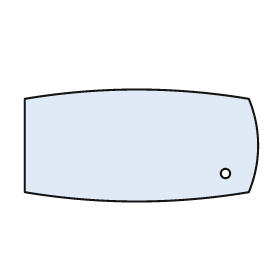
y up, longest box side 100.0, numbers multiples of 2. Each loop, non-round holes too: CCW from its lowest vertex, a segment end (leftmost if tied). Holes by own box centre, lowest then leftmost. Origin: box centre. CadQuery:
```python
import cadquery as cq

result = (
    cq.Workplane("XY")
    .moveTo(-50.0, -20.0)
    .threePointArc((-2.0, -24.0), (46.0, -20.0))
    .threePointArc((50.0, 0.0), (46.0, 20.0))
    .threePointArc((-2.0, 24.0), (-50.0, 20.0))
    .close()
    .moveTo(36.0, -12.0)
    .circle(2.0)
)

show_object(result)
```